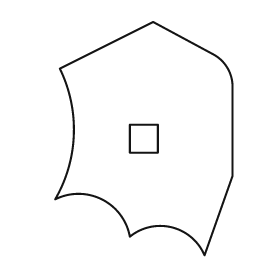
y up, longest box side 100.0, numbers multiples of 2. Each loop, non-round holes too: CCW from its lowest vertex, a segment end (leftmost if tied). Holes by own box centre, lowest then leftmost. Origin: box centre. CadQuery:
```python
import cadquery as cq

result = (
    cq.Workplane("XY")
    .moveTo(26.0, -50.0)
    .lineTo(38.0, -16.0)
    .lineTo(38.0, 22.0)
    .threePointArc((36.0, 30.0), (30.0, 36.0))
    .lineTo(4.0, 50.0)
    .lineTo(-36.0, 30.0)
    .threePointArc((-30.0, 2.0), (-38.0, -26.0))
    .threePointArc((-18.0, -26.0), (-6.0, -42.0))
    .threePointArc((12.0, -38.0), (26.0, -50.0))
    .close()
    .moveTo(-6.0, -6.0)
    .lineTo(6.0, -6.0)
    .lineTo(6.0, 6.0)
    .lineTo(-6.0, 6.0)
    .close()
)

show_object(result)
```